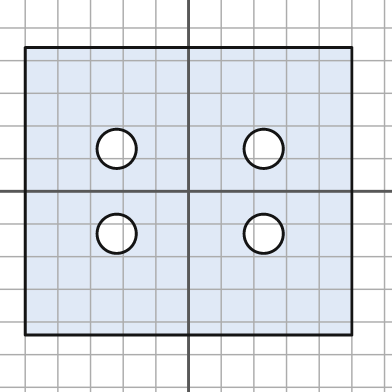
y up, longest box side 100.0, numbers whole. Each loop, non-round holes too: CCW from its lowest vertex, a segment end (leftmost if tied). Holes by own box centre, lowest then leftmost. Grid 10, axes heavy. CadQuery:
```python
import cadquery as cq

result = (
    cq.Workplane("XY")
    .moveTo(-50.0, -44.0)
    .lineTo(50.0, -44.0)
    .lineTo(50.0, 44.0)
    .lineTo(-50.0, 44.0)
    .close()
    .moveTo(-22.0, -13.0)
    .circle(6.0)
    .moveTo(23.0, -13.0)
    .circle(6.0)
    .moveTo(-22.0, 13.0)
    .circle(6.0)
    .moveTo(23.0, 13.0)
    .circle(6.0)
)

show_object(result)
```